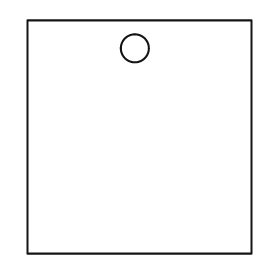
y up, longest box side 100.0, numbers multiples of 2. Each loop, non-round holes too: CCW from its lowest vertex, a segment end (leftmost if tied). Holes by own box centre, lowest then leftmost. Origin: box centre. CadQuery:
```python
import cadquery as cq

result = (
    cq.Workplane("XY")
    .moveTo(-48.0, -50.0)
    .lineTo(48.0, -50.0)
    .lineTo(48.0, 50.0)
    .lineTo(-48.0, 50.0)
    .close()
    .moveTo(-2.0, 38.0)
    .circle(6.0)
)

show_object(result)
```